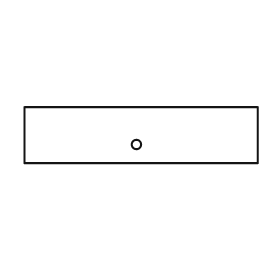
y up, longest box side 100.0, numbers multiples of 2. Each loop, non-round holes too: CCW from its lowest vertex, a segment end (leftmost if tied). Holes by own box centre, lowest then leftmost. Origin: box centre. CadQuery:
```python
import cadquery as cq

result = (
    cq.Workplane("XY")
    .moveTo(-50.0, -12.0)
    .lineTo(50.0, -12.0)
    .lineTo(50.0, 12.0)
    .lineTo(-50.0, 12.0)
    .close()
    .moveTo(-2.0, -4.0)
    .circle(2.0)
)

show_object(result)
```